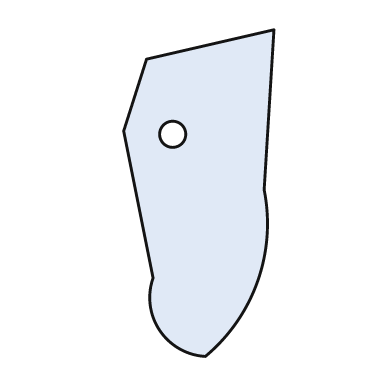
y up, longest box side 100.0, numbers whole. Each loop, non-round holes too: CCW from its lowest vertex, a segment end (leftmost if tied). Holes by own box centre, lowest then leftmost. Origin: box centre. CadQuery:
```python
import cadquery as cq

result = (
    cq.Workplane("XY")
    .moveTo(2.0, -50.0)
    .threePointArc((18.0, -27.0), (20.0, 1.0))
    .lineTo(23.0, 50.0)
    .lineTo(-16.0, 41.0)
    .lineTo(-23.0, 19.0)
    .lineTo(-14.0, -26.0)
    .threePointArc((-12.0, -42.0), (2.0, -50.0))
    .close()
    .moveTo(-8.0, 18.0)
    .circle(4.0)
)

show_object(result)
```